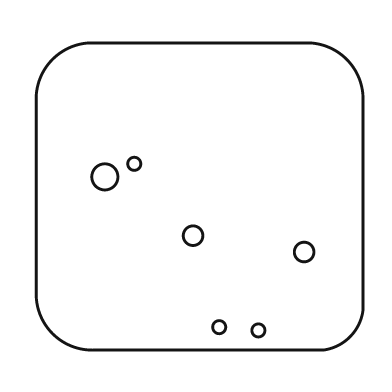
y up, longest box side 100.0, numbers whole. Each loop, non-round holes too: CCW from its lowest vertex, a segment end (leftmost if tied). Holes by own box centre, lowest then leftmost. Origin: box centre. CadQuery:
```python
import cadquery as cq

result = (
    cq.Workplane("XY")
    .moveTo(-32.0, -47.0)
    .lineTo(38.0, -47.0)
    .threePointArc((46.0, -43.0), (50.0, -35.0))
    .lineTo(50.0, 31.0)
    .threePointArc((45.0, 42.0), (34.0, 47.0))
    .lineTo(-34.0, 47.0)
    .threePointArc((-45.0, 42.0), (-50.0, 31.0))
    .lineTo(-50.0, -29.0)
    .threePointArc((-45.0, -42.0), (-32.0, -47.0))
    .close()
    .moveTo(18.0, -41.0)
    .circle(2.0)
    .moveTo(6.0, -40.0)
    .circle(2.0)
    .moveTo(32.0, -17.0)
    .circle(3.0)
    .moveTo(-2.0, -12.0)
    .circle(3.0)
    .moveTo(-29.0, 6.0)
    .circle(4.0)
    .moveTo(-20.0, 10.0)
    .circle(2.0)
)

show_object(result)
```